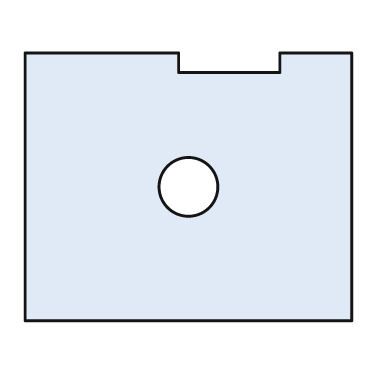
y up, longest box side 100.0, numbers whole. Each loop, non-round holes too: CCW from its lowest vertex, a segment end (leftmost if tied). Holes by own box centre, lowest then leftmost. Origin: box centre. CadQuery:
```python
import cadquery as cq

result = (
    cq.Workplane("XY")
    .moveTo(-50.0, -41.0)
    .lineTo(50.0, -41.0)
    .lineTo(50.0, 41.0)
    .lineTo(28.0, 41.0)
    .lineTo(28.0, 35.0)
    .lineTo(-3.0, 35.0)
    .lineTo(-3.0, 41.0)
    .lineTo(-50.0, 41.0)
    .close()
    .moveTo(0.0, 0.0)
    .circle(9.0)
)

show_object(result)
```